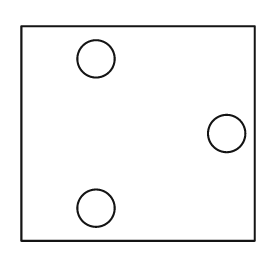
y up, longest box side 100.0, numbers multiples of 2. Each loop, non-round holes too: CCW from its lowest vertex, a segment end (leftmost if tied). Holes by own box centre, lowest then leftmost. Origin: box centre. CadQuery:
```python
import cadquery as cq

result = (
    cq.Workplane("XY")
    .moveTo(-50.0, -46.0)
    .lineTo(50.0, -46.0)
    .lineTo(50.0, 46.0)
    .lineTo(-50.0, 46.0)
    .close()
    .moveTo(-18.0, -32.0)
    .circle(8.0)
    .moveTo(38.0, 0.0)
    .circle(8.0)
    .moveTo(-18.0, 32.0)
    .circle(8.0)
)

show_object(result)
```